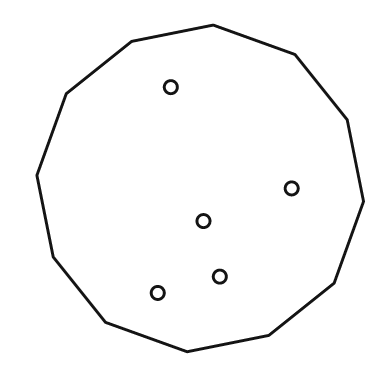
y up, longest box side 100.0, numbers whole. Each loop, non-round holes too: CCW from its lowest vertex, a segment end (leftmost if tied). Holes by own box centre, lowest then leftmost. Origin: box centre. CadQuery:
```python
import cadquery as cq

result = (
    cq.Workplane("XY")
    .moveTo(-4.0, -50.0)
    .lineTo(21.0, -45.0)
    .lineTo(41.0, -29.0)
    .lineTo(50.0, -4.0)
    .lineTo(45.0, 21.0)
    .lineTo(29.0, 41.0)
    .lineTo(4.0, 50.0)
    .lineTo(-21.0, 45.0)
    .lineTo(-41.0, 29.0)
    .lineTo(-50.0, 4.0)
    .lineTo(-45.0, -21.0)
    .lineTo(-29.0, -41.0)
    .close()
    .moveTo(-13.0, -32.0)
    .circle(2.0)
    .moveTo(6.0, -27.0)
    .circle(2.0)
    .moveTo(1.0, -10.0)
    .circle(2.0)
    .moveTo(28.0, 0.0)
    .circle(2.0)
    .moveTo(-9.0, 31.0)
    .circle(2.0)
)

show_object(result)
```